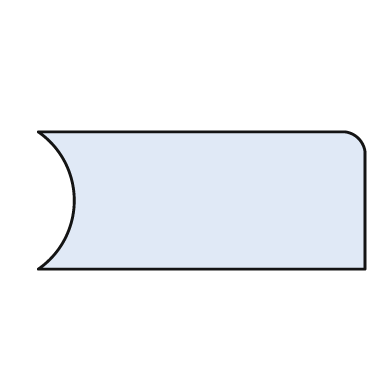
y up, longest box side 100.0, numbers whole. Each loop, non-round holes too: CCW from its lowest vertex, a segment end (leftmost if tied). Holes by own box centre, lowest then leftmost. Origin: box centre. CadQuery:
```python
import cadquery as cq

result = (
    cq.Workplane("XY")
    .moveTo(-50.0, -21.0)
    .lineTo(50.0, -21.0)
    .lineTo(50.0, 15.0)
    .threePointArc((48.0, 19.0), (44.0, 21.0))
    .lineTo(-50.0, 21.0)
    .threePointArc((-39.0, 0.0), (-50.0, -21.0))
    .close()
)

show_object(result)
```